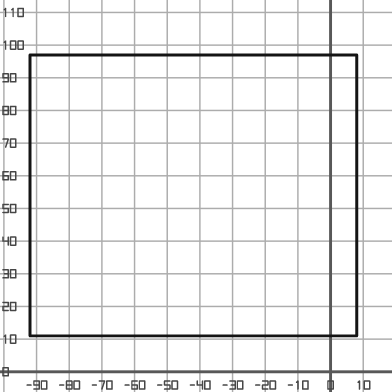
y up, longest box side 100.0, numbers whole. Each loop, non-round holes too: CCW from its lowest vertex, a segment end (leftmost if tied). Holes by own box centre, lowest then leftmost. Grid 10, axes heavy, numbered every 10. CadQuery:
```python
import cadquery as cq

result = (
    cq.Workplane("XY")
    .moveTo(-92.0, 11.0)
    .lineTo(8.0, 11.0)
    .lineTo(8.0, 97.0)
    .lineTo(-92.0, 97.0)
    .close()
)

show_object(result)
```